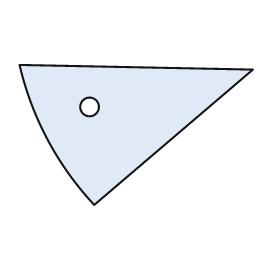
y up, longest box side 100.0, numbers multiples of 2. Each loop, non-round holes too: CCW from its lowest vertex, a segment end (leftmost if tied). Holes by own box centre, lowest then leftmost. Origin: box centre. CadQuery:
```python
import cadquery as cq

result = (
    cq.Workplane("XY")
    .moveTo(-18.0, -30.0)
    .lineTo(50.0, 28.0)
    .lineTo(-50.0, 30.0)
    .threePointArc((-38.0, -2.0), (-18.0, -30.0))
    .close()
    .moveTo(-20.0, 12.0)
    .circle(4.0)
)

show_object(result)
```